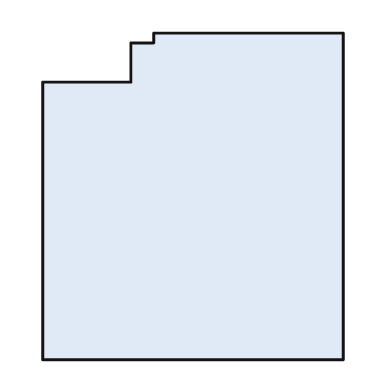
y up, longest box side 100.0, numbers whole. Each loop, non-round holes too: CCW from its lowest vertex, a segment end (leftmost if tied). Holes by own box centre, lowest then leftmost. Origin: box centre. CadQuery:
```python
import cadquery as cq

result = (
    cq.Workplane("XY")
    .moveTo(-46.0, -50.0)
    .lineTo(46.0, -50.0)
    .lineTo(46.0, 50.0)
    .lineTo(-12.0, 50.0)
    .lineTo(-12.0, 47.0)
    .lineTo(-19.0, 47.0)
    .lineTo(-19.0, 35.0)
    .lineTo(-46.0, 35.0)
    .close()
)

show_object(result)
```